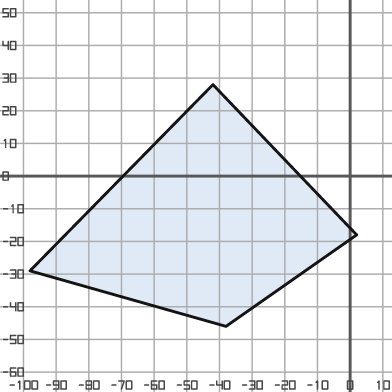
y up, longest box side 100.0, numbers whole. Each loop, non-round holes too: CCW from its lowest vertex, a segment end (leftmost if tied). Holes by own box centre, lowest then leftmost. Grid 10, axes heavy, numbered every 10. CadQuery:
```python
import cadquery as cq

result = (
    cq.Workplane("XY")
    .moveTo(-38.0, -46.0)
    .lineTo(2.0, -18.0)
    .lineTo(-42.0, 28.0)
    .lineTo(-98.0, -29.0)
    .close()
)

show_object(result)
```